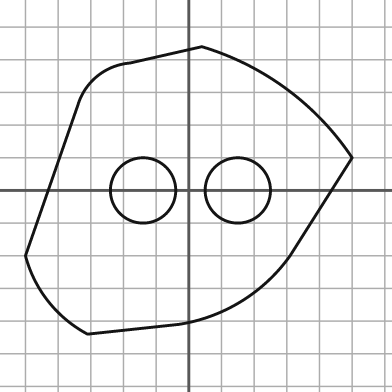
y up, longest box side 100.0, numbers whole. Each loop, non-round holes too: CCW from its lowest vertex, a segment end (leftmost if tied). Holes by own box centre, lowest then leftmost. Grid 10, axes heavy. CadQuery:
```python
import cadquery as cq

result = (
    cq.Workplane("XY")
    .moveTo(-31.0, -44.0)
    .lineTo(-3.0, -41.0)
    .threePointArc((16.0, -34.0), (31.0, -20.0))
    .lineTo(50.0, 10.0)
    .threePointArc((30.0, 31.0), (4.0, 44.0))
    .lineTo(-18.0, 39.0)
    .threePointArc((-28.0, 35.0), (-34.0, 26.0))
    .lineTo(-50.0, -20.0)
    .threePointArc((-43.0, -34.0), (-31.0, -44.0))
    .close()
    .moveTo(-14.0, 0.0)
    .circle(10.0)
    .moveTo(15.0, 0.0)
    .circle(10.0)
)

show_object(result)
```